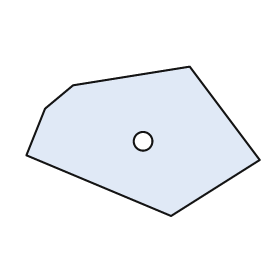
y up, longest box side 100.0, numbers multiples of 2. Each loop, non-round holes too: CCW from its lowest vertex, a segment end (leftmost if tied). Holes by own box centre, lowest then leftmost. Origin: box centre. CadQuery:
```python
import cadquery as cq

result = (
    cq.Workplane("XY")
    .moveTo(12.0, -32.0)
    .lineTo(50.0, -8.0)
    .lineTo(20.0, 32.0)
    .lineTo(-30.0, 24.0)
    .lineTo(-42.0, 14.0)
    .lineTo(-50.0, -6.0)
    .close()
    .moveTo(0.0, 0.0)
    .circle(4.0)
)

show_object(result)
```